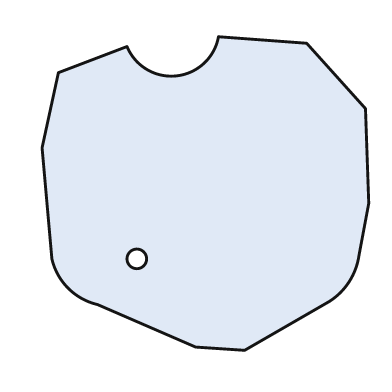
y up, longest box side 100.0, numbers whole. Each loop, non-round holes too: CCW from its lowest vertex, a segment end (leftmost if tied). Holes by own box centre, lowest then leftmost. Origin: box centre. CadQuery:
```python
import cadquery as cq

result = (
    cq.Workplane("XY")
    .moveTo(12.0, -48.0)
    .lineTo(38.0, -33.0)
    .threePointArc((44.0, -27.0), (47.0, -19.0))
    .lineTo(50.0, -3.0)
    .lineTo(49.0, 26.0)
    .lineTo(31.0, 46.0)
    .lineTo(4.0, 48.0)
    .threePointArc((-9.0, 36.0), (-24.0, 45.0))
    .lineTo(-45.0, 37.0)
    .lineTo(-50.0, 14.0)
    .lineTo(-47.0, -20.0)
    .threePointArc((-42.0, -29.0), (-33.0, -34.0))
    .lineTo(-3.0, -47.0)
    .close()
    .moveTo(-21.0, -20.0)
    .circle(3.0)
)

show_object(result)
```